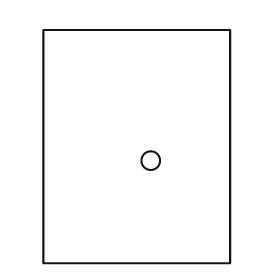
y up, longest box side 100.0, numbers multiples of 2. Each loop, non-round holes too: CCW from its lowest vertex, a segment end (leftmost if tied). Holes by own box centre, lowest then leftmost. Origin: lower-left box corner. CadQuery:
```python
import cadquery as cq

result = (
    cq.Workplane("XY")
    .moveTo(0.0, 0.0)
    .lineTo(80.0, 0.0)
    .lineTo(80.0, 100.0)
    .lineTo(0.0, 100.0)
    .close()
    .moveTo(46.0, 44.0)
    .circle(4.0)
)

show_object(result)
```